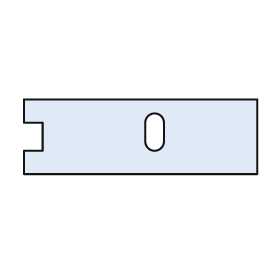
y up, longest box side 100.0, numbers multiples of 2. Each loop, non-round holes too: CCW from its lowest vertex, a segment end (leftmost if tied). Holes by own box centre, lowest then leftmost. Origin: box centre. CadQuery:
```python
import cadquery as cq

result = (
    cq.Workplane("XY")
    .moveTo(-50.0, -16.0)
    .lineTo(50.0, -16.0)
    .lineTo(50.0, 16.0)
    .lineTo(-50.0, 16.0)
    .lineTo(-50.0, 6.0)
    .lineTo(-42.0, 6.0)
    .lineTo(-42.0, -6.0)
    .lineTo(-50.0, -6.0)
    .close()
    .moveTo(2.0, -2.0)
    .threePointArc((6.0, -6.0), (10.0, -2.0))
    .lineTo(10.0, 6.0)
    .threePointArc((6.0, 10.0), (2.0, 6.0))
    .close()
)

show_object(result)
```